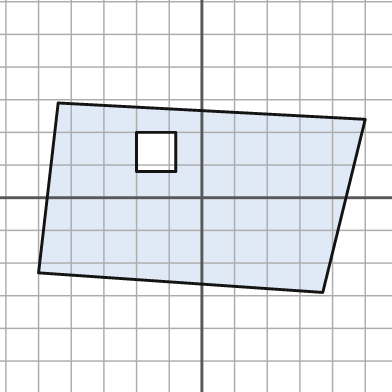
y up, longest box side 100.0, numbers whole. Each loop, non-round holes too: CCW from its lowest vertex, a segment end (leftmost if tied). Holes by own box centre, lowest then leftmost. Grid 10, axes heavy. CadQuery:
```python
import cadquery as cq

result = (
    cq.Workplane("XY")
    .moveTo(37.0, -29.0)
    .lineTo(50.0, 24.0)
    .lineTo(-44.0, 29.0)
    .lineTo(-50.0, -23.0)
    .close()
    .moveTo(-20.0, 8.0)
    .lineTo(-8.0, 8.0)
    .lineTo(-8.0, 20.0)
    .lineTo(-20.0, 20.0)
    .close()
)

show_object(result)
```